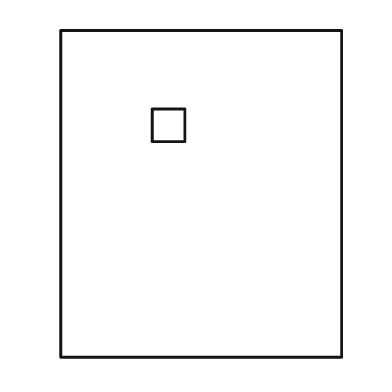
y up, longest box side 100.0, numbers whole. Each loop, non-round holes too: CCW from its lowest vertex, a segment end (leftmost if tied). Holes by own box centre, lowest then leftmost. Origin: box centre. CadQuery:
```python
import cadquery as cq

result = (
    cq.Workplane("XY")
    .moveTo(-43.0, -50.0)
    .lineTo(43.0, -50.0)
    .lineTo(43.0, 50.0)
    .lineTo(-43.0, 50.0)
    .close()
    .moveTo(-15.0, 16.0)
    .lineTo(-5.0, 16.0)
    .lineTo(-5.0, 26.0)
    .lineTo(-15.0, 26.0)
    .close()
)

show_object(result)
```